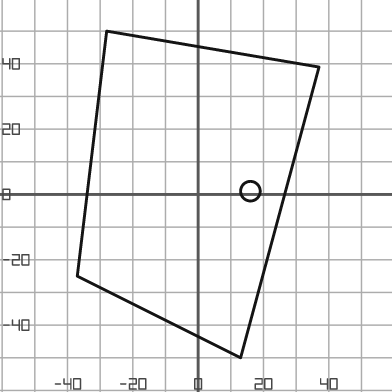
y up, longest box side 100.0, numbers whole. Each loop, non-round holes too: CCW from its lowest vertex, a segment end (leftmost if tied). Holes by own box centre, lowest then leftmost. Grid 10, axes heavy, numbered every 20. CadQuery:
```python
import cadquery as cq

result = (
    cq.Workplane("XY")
    .moveTo(13.0, -50.0)
    .lineTo(37.0, 39.0)
    .lineTo(-28.0, 50.0)
    .lineTo(-37.0, -25.0)
    .close()
    .moveTo(16.0, 1.0)
    .circle(3.0)
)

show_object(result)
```